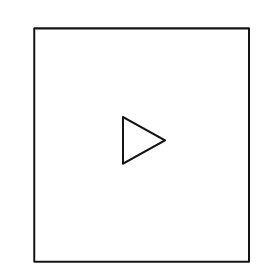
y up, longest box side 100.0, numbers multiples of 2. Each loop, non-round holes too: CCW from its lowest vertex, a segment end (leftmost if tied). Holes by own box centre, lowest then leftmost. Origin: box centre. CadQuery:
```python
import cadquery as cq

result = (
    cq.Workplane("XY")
    .moveTo(-46.0, -50.0)
    .lineTo(46.0, -50.0)
    .lineTo(46.0, 50.0)
    .lineTo(-46.0, 50.0)
    .close()
    .moveTo(-8.0, -8.0)
    .lineTo(10.0, 2.0)
    .lineTo(-8.0, 12.0)
    .close()
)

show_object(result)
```